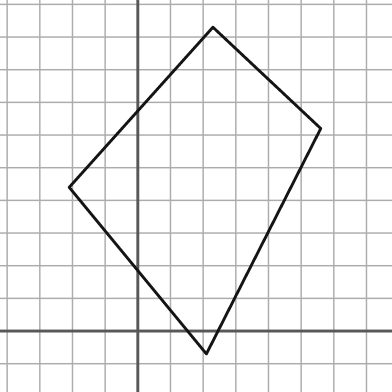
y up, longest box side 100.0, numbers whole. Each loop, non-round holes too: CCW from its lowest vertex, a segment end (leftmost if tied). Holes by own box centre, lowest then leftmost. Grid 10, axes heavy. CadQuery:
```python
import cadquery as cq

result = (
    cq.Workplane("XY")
    .moveTo(21.0, -7.0)
    .lineTo(56.0, 62.0)
    .lineTo(23.0, 93.0)
    .lineTo(-21.0, 44.0)
    .close()
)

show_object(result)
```